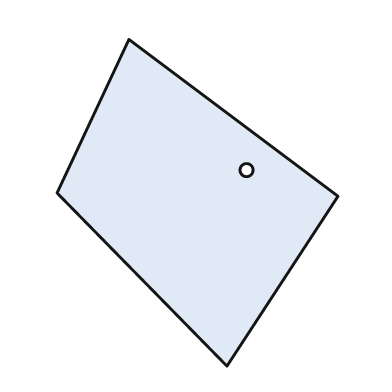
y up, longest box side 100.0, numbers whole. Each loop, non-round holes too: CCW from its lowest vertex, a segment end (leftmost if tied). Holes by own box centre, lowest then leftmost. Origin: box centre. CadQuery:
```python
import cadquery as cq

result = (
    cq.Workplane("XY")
    .moveTo(9.0, -50.0)
    .lineTo(43.0, 2.0)
    .lineTo(-21.0, 50.0)
    .lineTo(-43.0, 3.0)
    .close()
    .moveTo(15.0, 10.0)
    .circle(2.0)
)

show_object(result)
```